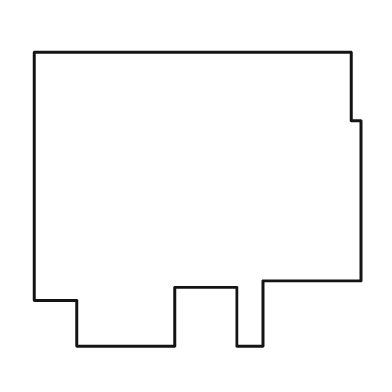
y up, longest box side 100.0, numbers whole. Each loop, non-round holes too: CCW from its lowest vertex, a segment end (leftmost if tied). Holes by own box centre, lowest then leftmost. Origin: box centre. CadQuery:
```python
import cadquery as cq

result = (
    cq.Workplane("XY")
    .moveTo(-37.0, -45.0)
    .lineTo(-7.0, -45.0)
    .lineTo(-7.0, -27.0)
    .lineTo(12.0, -27.0)
    .lineTo(12.0, -45.0)
    .lineTo(20.0, -45.0)
    .lineTo(20.0, -25.0)
    .lineTo(50.0, -25.0)
    .lineTo(50.0, 24.0)
    .lineTo(47.0, 24.0)
    .lineTo(47.0, 45.0)
    .lineTo(-50.0, 45.0)
    .lineTo(-50.0, -31.0)
    .lineTo(-37.0, -31.0)
    .close()
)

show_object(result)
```